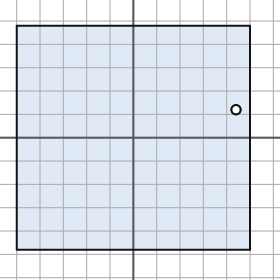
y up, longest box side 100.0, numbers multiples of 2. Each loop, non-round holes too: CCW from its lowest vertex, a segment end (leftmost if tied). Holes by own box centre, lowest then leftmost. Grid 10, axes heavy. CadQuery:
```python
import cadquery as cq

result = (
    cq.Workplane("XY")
    .moveTo(-50.0, -48.0)
    .lineTo(50.0, -48.0)
    .lineTo(50.0, 48.0)
    .lineTo(-50.0, 48.0)
    .close()
    .moveTo(44.0, 12.0)
    .circle(2.0)
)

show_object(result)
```